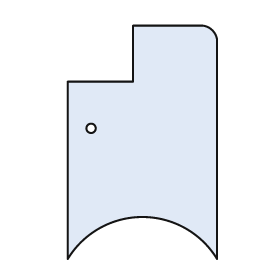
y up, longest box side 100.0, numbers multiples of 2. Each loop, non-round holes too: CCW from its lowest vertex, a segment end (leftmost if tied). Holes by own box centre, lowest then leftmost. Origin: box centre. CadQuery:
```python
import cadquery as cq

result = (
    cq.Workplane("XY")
    .moveTo(-32.0, -50.0)
    .threePointArc((0.0, -32.0), (32.0, -50.0))
    .lineTo(32.0, 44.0)
    .threePointArc((30.0, 48.0), (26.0, 50.0))
    .lineTo(-4.0, 50.0)
    .lineTo(-4.0, 26.0)
    .lineTo(-32.0, 26.0)
    .close()
    .moveTo(-22.0, 6.0)
    .circle(2.0)
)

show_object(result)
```